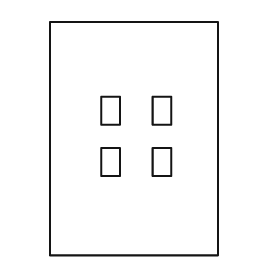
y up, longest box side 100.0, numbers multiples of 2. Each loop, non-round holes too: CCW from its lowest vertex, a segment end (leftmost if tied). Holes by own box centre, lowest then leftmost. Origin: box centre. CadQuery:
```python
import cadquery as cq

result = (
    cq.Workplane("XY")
    .moveTo(-36.0, -50.0)
    .lineTo(36.0, -50.0)
    .lineTo(36.0, 50.0)
    .lineTo(-36.0, 50.0)
    .close()
    .moveTo(-14.0, -16.0)
    .lineTo(-6.0, -16.0)
    .lineTo(-6.0, -4.0)
    .lineTo(-14.0, -4.0)
    .close()
    .moveTo(8.0, -16.0)
    .lineTo(16.0, -16.0)
    .lineTo(16.0, -4.0)
    .lineTo(8.0, -4.0)
    .close()
    .moveTo(-14.0, 6.0)
    .lineTo(-6.0, 6.0)
    .lineTo(-6.0, 18.0)
    .lineTo(-14.0, 18.0)
    .close()
    .moveTo(8.0, 6.0)
    .lineTo(16.0, 6.0)
    .lineTo(16.0, 18.0)
    .lineTo(8.0, 18.0)
    .close()
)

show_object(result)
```